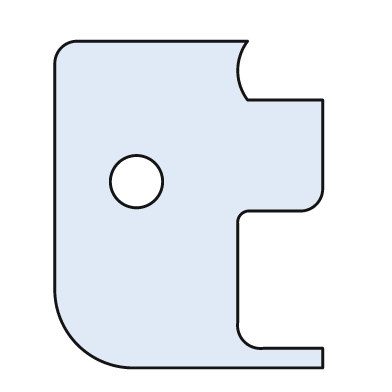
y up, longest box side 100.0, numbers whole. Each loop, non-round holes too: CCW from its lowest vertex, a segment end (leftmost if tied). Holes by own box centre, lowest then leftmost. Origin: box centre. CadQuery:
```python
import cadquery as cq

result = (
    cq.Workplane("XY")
    .moveTo(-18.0, -50.0)
    .lineTo(41.0, -50.0)
    .lineTo(41.0, -44.0)
    .lineTo(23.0, -44.0)
    .threePointArc((17.0, -42.0), (15.0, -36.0))
    .lineTo(15.0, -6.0)
    .threePointArc((16.0, -3.0), (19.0, -2.0))
    .lineTo(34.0, -2.0)
    .threePointArc((39.0, 0.0), (41.0, 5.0))
    .lineTo(41.0, 32.0)
    .lineTo(18.0, 32.0)
    .threePointArc((15.0, 41.0), (18.0, 50.0))
    .lineTo(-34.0, 50.0)
    .threePointArc((-39.0, 48.0), (-41.0, 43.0))
    .lineTo(-41.0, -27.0)
    .threePointArc((-34.0, -43.0), (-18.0, -50.0))
    .close()
    .moveTo(-16.0, 7.0)
    .circle(8.0)
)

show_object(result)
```